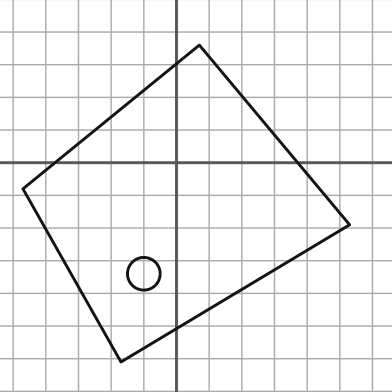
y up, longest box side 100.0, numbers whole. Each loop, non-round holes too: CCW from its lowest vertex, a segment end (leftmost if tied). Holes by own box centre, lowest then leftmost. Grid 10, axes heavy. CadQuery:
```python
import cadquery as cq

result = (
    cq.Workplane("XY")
    .moveTo(-17.0, -61.0)
    .lineTo(53.0, -19.0)
    .lineTo(7.0, 36.0)
    .lineTo(-47.0, -8.0)
    .close()
    .moveTo(-10.0, -34.0)
    .circle(5.0)
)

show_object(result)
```